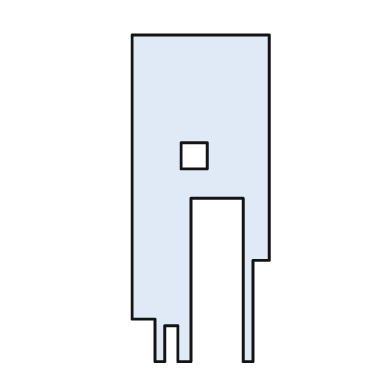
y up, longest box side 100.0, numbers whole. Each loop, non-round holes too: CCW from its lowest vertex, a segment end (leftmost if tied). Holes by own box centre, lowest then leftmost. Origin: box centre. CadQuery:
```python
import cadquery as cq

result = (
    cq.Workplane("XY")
    .moveTo(-14.0, -50.0)
    .lineTo(-11.0, -50.0)
    .lineTo(-11.0, -39.0)
    .lineTo(-7.0, -39.0)
    .lineTo(-7.0, -50.0)
    .lineTo(-3.0, -50.0)
    .lineTo(-3.0, 0.0)
    .lineTo(13.0, 0.0)
    .lineTo(13.0, -50.0)
    .lineTo(16.0, -50.0)
    .lineTo(16.0, -19.0)
    .lineTo(21.0, -19.0)
    .lineTo(21.0, 50.0)
    .lineTo(-21.0, 50.0)
    .lineTo(-21.0, -37.0)
    .lineTo(-14.0, -37.0)
    .close()
    .moveTo(-6.0, 9.0)
    .lineTo(2.0, 9.0)
    .lineTo(2.0, 17.0)
    .lineTo(-6.0, 17.0)
    .close()
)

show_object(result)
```